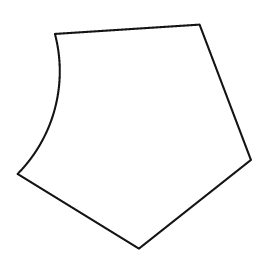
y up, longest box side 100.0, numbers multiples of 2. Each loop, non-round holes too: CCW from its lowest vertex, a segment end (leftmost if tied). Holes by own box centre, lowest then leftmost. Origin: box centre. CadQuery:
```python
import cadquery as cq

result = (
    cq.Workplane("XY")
    .moveTo(2.0, -48.0)
    .lineTo(50.0, -10.0)
    .lineTo(28.0, 48.0)
    .lineTo(-34.0, 44.0)
    .threePointArc((-34.0, 12.0), (-50.0, -16.0))
    .close()
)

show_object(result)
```